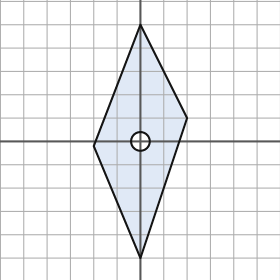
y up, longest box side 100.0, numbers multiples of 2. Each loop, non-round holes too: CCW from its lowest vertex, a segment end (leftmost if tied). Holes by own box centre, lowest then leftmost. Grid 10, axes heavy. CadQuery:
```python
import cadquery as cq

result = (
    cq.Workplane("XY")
    .moveTo(0.0, -50.0)
    .lineTo(20.0, 10.0)
    .lineTo(0.0, 50.0)
    .lineTo(-20.0, -2.0)
    .close()
    .moveTo(0.0, 0.0)
    .circle(4.0)
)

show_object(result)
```